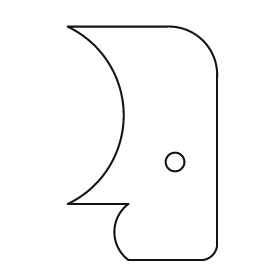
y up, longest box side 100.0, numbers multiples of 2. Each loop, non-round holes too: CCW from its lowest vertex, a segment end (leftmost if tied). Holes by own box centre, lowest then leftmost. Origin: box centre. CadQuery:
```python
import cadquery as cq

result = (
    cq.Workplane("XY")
    .moveTo(-6.0, -50.0)
    .lineTo(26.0, -50.0)
    .threePointArc((30.0, -48.0), (32.0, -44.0))
    .lineTo(32.0, 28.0)
    .threePointArc((26.0, 44.0), (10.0, 50.0))
    .lineTo(-32.0, 50.0)
    .threePointArc((-8.0, 12.0), (-32.0, -26.0))
    .lineTo(-6.0, -26.0)
    .threePointArc((-12.0, -38.0), (-6.0, -50.0))
    .close()
    .moveTo(14.0, -8.0)
    .circle(4.0)
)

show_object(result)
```